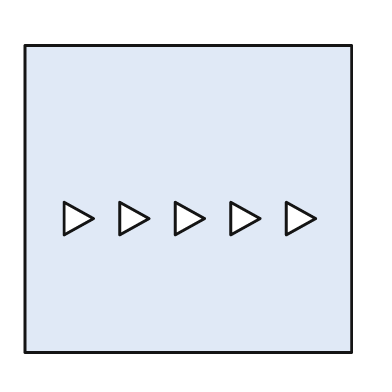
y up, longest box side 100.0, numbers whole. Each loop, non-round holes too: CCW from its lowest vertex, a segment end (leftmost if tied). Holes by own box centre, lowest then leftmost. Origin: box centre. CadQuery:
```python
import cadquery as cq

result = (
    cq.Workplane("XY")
    .moveTo(-50.0, -47.0)
    .lineTo(50.0, -47.0)
    .lineTo(50.0, 47.0)
    .lineTo(-50.0, 47.0)
    .close()
    .moveTo(-38.0, -11.0)
    .lineTo(-29.0, -6.0)
    .lineTo(-38.0, -1.0)
    .close()
    .moveTo(-21.0, -11.0)
    .lineTo(-12.0, -6.0)
    .lineTo(-21.0, -1.0)
    .close()
    .moveTo(-4.0, -11.0)
    .lineTo(5.0, -6.0)
    .lineTo(-4.0, -1.0)
    .close()
    .moveTo(13.0, -11.0)
    .lineTo(22.0, -6.0)
    .lineTo(13.0, -1.0)
    .close()
    .moveTo(30.0, -11.0)
    .lineTo(39.0, -6.0)
    .lineTo(30.0, -1.0)
    .close()
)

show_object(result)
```